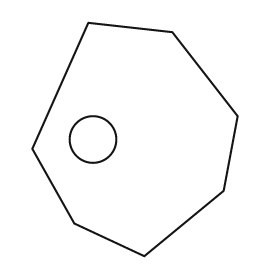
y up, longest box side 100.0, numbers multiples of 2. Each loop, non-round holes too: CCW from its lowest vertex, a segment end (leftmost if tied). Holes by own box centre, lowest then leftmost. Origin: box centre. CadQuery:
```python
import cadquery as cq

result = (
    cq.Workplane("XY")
    .moveTo(4.0, -50.0)
    .lineTo(38.0, -22.0)
    .lineTo(44.0, 10.0)
    .lineTo(16.0, 46.0)
    .lineTo(-20.0, 50.0)
    .lineTo(-44.0, -4.0)
    .lineTo(-26.0, -36.0)
    .close()
    .moveTo(-18.0, 0.0)
    .circle(10.0)
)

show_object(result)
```